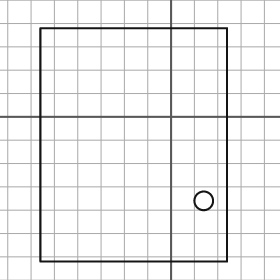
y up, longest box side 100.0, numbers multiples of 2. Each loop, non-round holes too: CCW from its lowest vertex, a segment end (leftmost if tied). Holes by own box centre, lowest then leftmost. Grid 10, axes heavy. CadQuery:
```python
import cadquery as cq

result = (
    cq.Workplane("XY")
    .moveTo(-56.0, -62.0)
    .lineTo(24.0, -62.0)
    .lineTo(24.0, 38.0)
    .lineTo(-56.0, 38.0)
    .close()
    .moveTo(14.0, -36.0)
    .circle(4.0)
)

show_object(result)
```